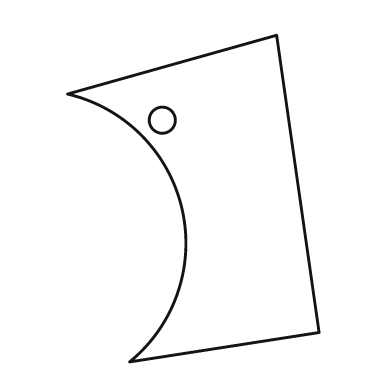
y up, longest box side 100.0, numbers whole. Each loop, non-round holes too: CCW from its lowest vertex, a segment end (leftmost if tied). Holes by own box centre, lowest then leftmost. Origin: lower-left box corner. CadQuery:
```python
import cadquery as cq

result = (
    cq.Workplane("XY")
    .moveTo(19.0, 0.0)
    .lineTo(77.0, 9.0)
    .lineTo(64.0, 100.0)
    .lineTo(0.0, 82.0)
    .threePointArc((35.0, 47.0), (19.0, 0.0))
    .close()
    .moveTo(29.0, 74.0)
    .circle(4.0)
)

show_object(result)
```